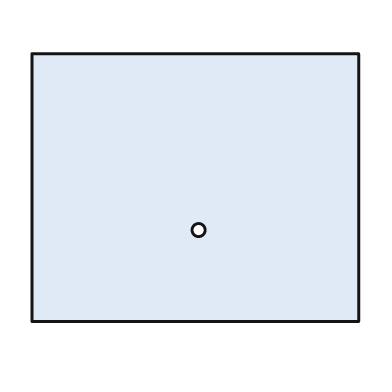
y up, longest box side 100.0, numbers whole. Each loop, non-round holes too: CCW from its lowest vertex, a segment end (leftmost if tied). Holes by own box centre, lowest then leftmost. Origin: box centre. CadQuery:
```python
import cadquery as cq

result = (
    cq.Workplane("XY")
    .moveTo(-50.0, -41.0)
    .lineTo(50.0, -41.0)
    .lineTo(50.0, 41.0)
    .lineTo(-50.0, 41.0)
    .close()
    .moveTo(1.0, -13.0)
    .circle(2.0)
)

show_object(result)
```